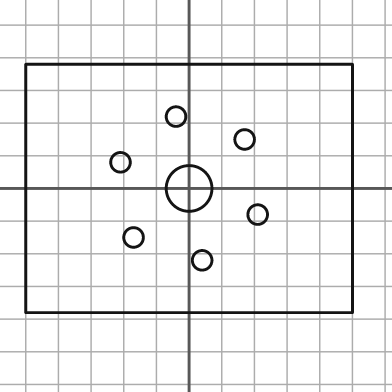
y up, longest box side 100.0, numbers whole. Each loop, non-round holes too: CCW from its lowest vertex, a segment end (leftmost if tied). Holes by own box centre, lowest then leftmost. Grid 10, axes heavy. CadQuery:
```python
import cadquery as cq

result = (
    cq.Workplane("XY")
    .moveTo(-50.0, -38.0)
    .lineTo(50.0, -38.0)
    .lineTo(50.0, 38.0)
    .lineTo(-50.0, 38.0)
    .close()
    .moveTo(4.0, -22.0)
    .circle(3.0)
    .moveTo(-17.0, -15.0)
    .circle(3.0)
    .moveTo(21.0, -8.0)
    .circle(3.0)
    .moveTo(0.0, 0.0)
    .circle(7.0)
    .moveTo(-21.0, 8.0)
    .circle(3.0)
    .moveTo(17.0, 15.0)
    .circle(3.0)
    .moveTo(-4.0, 22.0)
    .circle(3.0)
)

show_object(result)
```